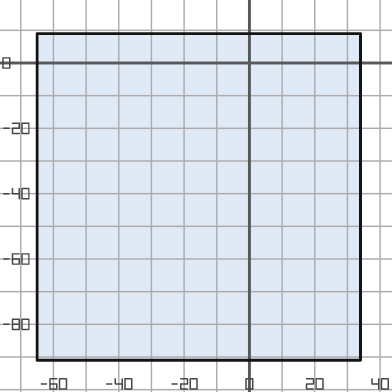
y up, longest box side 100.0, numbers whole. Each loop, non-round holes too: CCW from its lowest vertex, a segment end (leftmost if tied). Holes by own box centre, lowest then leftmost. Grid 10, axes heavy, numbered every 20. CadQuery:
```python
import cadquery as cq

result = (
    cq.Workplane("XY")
    .moveTo(-65.0, -91.0)
    .lineTo(34.0, -91.0)
    .lineTo(34.0, 9.0)
    .lineTo(-65.0, 9.0)
    .close()
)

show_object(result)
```